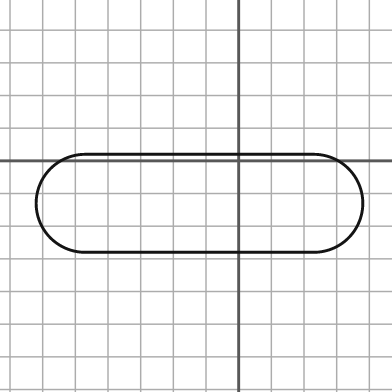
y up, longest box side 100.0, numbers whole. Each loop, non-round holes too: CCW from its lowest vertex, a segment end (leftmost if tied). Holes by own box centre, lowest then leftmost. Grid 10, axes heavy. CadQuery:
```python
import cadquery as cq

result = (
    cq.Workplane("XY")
    .moveTo(-47.0, -28.0)
    .lineTo(23.0, -28.0)
    .threePointArc((38.0, -13.0), (23.0, 2.0))
    .lineTo(-47.0, 2.0)
    .threePointArc((-62.0, -13.0), (-47.0, -28.0))
    .close()
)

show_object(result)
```